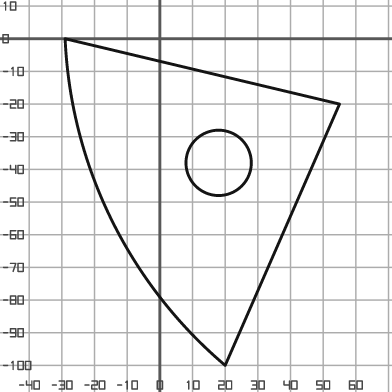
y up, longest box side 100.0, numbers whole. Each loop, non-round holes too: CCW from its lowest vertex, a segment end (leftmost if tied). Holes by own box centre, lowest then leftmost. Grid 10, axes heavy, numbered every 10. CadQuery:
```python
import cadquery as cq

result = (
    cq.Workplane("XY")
    .moveTo(20.0, -100.0)
    .lineTo(55.0, -20.0)
    .lineTo(-29.0, 0.0)
    .threePointArc((-15.0, -55.0), (20.0, -100.0))
    .close()
    .moveTo(18.0, -38.0)
    .circle(10.0)
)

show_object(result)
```